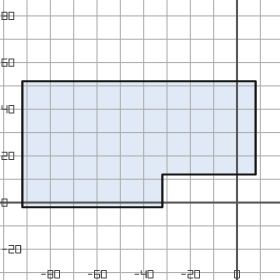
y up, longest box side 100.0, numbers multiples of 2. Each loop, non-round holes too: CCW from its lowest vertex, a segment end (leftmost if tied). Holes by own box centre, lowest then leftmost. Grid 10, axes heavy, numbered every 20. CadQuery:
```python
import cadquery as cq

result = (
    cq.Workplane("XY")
    .moveTo(-92.0, -2.0)
    .lineTo(-32.0, -2.0)
    .lineTo(-32.0, 12.0)
    .lineTo(8.0, 12.0)
    .lineTo(8.0, 52.0)
    .lineTo(-92.0, 52.0)
    .close()
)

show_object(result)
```